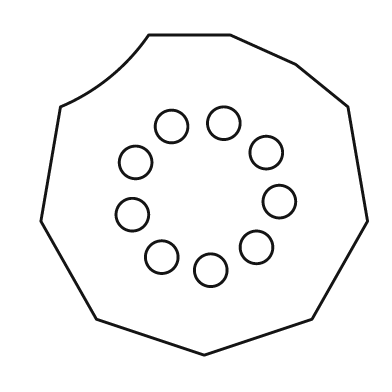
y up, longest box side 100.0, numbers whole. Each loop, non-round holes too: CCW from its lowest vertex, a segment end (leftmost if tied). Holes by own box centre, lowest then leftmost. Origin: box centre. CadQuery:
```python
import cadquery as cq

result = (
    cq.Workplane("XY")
    .moveTo(0.0, -49.0)
    .lineTo(33.0, -38.0)
    .lineTo(50.0, -8.0)
    .lineTo(44.0, 27.0)
    .lineTo(28.0, 40.0)
    .lineTo(8.0, 49.0)
    .lineTo(-17.0, 49.0)
    .threePointArc((-29.0, 36.0), (-44.0, 27.0))
    .lineTo(-50.0, -8.0)
    .lineTo(-33.0, -38.0)
    .close()
    .moveTo(2.0, -23.0)
    .circle(5.0)
    .moveTo(-13.0, -19.0)
    .circle(5.0)
    .moveTo(16.0, -16.0)
    .circle(5.0)
    .moveTo(-22.0, -6.0)
    .circle(5.0)
    .moveTo(23.0, -2.0)
    .circle(5.0)
    .moveTo(-21.0, 10.0)
    .circle(5.0)
    .moveTo(19.0, 13.0)
    .circle(5.0)
    .moveTo(-10.0, 21.0)
    .circle(5.0)
    .moveTo(6.0, 22.0)
    .circle(5.0)
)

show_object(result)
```